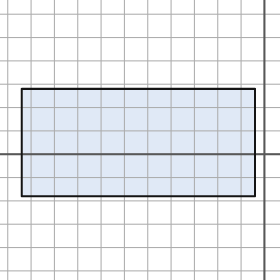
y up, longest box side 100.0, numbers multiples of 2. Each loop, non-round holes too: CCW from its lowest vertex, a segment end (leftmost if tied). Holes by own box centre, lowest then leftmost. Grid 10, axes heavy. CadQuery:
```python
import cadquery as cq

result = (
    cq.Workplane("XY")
    .moveTo(-104.0, -18.0)
    .lineTo(-4.0, -18.0)
    .lineTo(-4.0, 28.0)
    .lineTo(-104.0, 28.0)
    .close()
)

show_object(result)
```